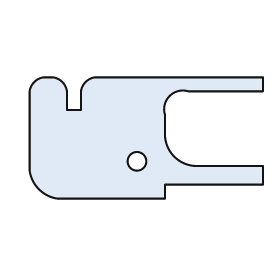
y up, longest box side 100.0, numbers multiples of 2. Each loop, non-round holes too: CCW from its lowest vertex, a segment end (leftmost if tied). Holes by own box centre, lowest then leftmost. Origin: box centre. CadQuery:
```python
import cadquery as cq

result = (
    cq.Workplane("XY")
    .moveTo(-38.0, -26.0)
    .lineTo(8.0, -26.0)
    .lineTo(8.0, -20.0)
    .lineTo(50.0, -20.0)
    .lineTo(50.0, -12.0)
    .lineTo(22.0, -12.0)
    .threePointArc((12.0, -8.0), (8.0, 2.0))
    .lineTo(8.0, 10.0)
    .threePointArc((10.0, 18.0), (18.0, 20.0))
    .lineTo(50.0, 20.0)
    .lineTo(50.0, 26.0)
    .lineTo(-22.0, 26.0)
    .threePointArc((-26.0, 24.0), (-28.0, 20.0))
    .lineTo(-28.0, 12.0)
    .lineTo(-34.0, 12.0)
    .lineTo(-34.0, 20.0)
    .threePointArc((-36.0, 24.0), (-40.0, 26.0))
    .lineTo(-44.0, 26.0)
    .threePointArc((-48.0, 24.0), (-50.0, 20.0))
    .lineTo(-50.0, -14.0)
    .threePointArc((-46.0, -22.0), (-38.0, -26.0))
    .close()
    .moveTo(-4.0, -10.0)
    .circle(4.0)
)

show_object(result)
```